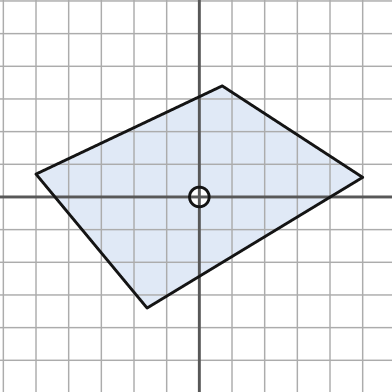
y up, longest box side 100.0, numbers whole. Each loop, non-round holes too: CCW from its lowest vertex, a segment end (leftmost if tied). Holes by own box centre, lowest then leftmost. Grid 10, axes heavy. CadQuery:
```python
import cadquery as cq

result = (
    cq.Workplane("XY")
    .moveTo(-16.0, -34.0)
    .lineTo(50.0, 6.0)
    .lineTo(7.0, 34.0)
    .lineTo(-50.0, 7.0)
    .close()
    .moveTo(0.0, 0.0)
    .circle(3.0)
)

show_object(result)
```